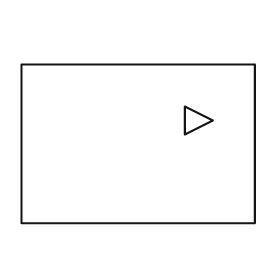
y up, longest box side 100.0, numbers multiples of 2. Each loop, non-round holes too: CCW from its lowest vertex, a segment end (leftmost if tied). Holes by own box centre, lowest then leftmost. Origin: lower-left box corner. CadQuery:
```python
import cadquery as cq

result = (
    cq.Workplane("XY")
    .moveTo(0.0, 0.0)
    .lineTo(100.0, 0.0)
    .lineTo(100.0, 68.0)
    .lineTo(0.0, 68.0)
    .close()
    .moveTo(70.0, 38.0)
    .lineTo(82.0, 44.0)
    .lineTo(70.0, 50.0)
    .close()
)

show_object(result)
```